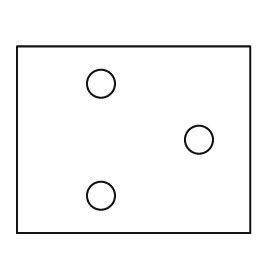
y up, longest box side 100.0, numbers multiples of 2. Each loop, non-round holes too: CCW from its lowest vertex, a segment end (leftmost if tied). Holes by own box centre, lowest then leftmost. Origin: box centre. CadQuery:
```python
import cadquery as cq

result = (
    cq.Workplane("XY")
    .moveTo(-50.0, -40.0)
    .lineTo(50.0, -40.0)
    .lineTo(50.0, 40.0)
    .lineTo(-50.0, 40.0)
    .close()
    .moveTo(-14.0, -24.0)
    .circle(6.0)
    .moveTo(28.0, 0.0)
    .circle(6.0)
    .moveTo(-14.0, 24.0)
    .circle(6.0)
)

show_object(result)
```